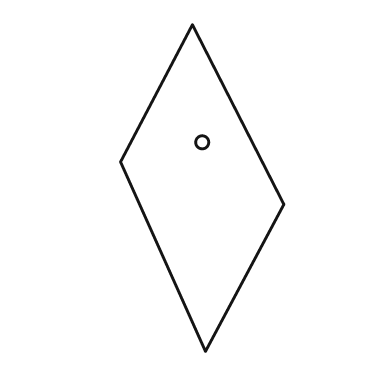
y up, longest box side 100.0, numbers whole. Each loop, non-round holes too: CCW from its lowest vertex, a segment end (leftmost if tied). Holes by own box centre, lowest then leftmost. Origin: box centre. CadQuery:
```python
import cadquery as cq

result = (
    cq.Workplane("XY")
    .moveTo(1.0, -50.0)
    .lineTo(25.0, -5.0)
    .lineTo(-3.0, 50.0)
    .lineTo(-25.0, 8.0)
    .close()
    .moveTo(0.0, 14.0)
    .circle(2.0)
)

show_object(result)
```